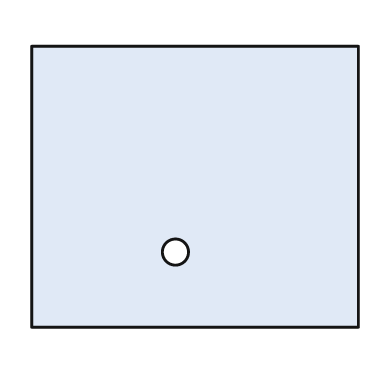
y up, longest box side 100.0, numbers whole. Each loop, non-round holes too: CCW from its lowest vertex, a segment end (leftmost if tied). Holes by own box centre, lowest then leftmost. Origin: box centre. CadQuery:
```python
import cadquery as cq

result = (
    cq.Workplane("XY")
    .moveTo(-50.0, -43.0)
    .lineTo(50.0, -43.0)
    .lineTo(50.0, 43.0)
    .lineTo(-50.0, 43.0)
    .close()
    .moveTo(-6.0, -20.0)
    .circle(4.0)
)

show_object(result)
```